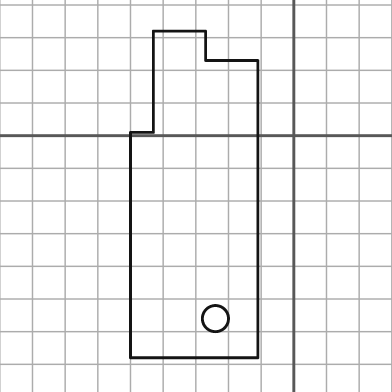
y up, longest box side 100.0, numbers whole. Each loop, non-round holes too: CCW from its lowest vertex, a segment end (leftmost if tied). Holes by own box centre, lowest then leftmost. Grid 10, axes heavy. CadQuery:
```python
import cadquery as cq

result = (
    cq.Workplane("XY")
    .moveTo(-50.0, -68.0)
    .lineTo(-11.0, -68.0)
    .lineTo(-11.0, 23.0)
    .lineTo(-27.0, 23.0)
    .lineTo(-27.0, 32.0)
    .lineTo(-43.0, 32.0)
    .lineTo(-43.0, 1.0)
    .lineTo(-50.0, 1.0)
    .close()
    .moveTo(-24.0, -56.0)
    .circle(4.0)
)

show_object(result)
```